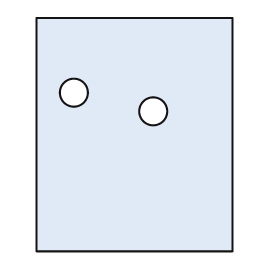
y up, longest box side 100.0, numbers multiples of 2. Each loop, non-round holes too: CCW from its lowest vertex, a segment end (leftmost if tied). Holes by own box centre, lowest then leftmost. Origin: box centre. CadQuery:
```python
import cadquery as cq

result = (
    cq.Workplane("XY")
    .moveTo(-42.0, -50.0)
    .lineTo(42.0, -50.0)
    .lineTo(42.0, 50.0)
    .lineTo(-42.0, 50.0)
    .close()
    .moveTo(8.0, 10.0)
    .circle(6.0)
    .moveTo(-26.0, 18.0)
    .circle(6.0)
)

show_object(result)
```